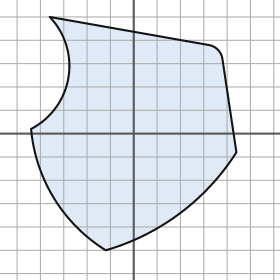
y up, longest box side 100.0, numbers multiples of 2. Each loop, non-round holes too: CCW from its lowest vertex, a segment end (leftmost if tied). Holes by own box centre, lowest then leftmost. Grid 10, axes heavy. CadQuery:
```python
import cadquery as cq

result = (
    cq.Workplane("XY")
    .moveTo(-12.0, -50.0)
    .threePointArc((20.0, -34.0), (44.0, -8.0))
    .lineTo(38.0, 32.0)
    .threePointArc((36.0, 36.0), (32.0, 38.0))
    .lineTo(-36.0, 50.0)
    .threePointArc((-28.0, 24.0), (-44.0, 2.0))
    .threePointArc((-34.0, -28.0), (-12.0, -50.0))
    .close()
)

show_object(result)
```